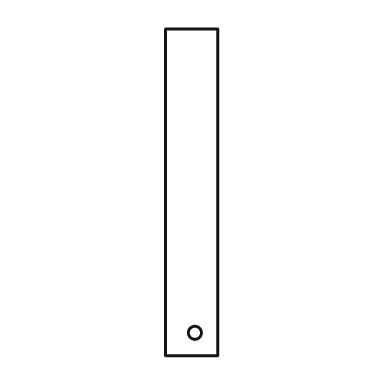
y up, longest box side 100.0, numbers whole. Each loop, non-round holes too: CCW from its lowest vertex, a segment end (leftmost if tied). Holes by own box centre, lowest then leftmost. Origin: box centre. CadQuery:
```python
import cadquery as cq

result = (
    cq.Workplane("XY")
    .moveTo(-8.0, -50.0)
    .lineTo(8.0, -50.0)
    .lineTo(8.0, 50.0)
    .lineTo(-8.0, 50.0)
    .close()
    .moveTo(1.0, -43.0)
    .circle(2.0)
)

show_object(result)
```